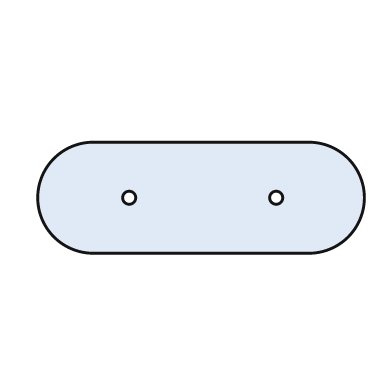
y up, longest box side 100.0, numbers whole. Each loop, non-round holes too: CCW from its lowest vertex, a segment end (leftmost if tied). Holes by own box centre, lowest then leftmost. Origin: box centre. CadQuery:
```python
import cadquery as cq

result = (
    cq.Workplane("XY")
    .moveTo(-33.0, -17.0)
    .lineTo(33.0, -17.0)
    .threePointArc((50.0, 0.0), (33.0, 17.0))
    .lineTo(-33.0, 17.0)
    .threePointArc((-50.0, 0.0), (-33.0, -17.0))
    .close()
    .moveTo(-22.0, 0.0)
    .circle(2.0)
    .moveTo(23.0, 0.0)
    .circle(2.0)
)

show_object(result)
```